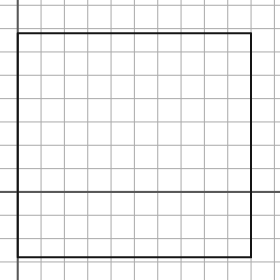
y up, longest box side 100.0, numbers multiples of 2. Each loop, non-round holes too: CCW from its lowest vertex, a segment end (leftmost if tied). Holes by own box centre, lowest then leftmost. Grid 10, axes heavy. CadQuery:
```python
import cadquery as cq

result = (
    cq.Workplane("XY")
    .moveTo(0.0, -28.0)
    .lineTo(100.0, -28.0)
    .lineTo(100.0, 68.0)
    .lineTo(0.0, 68.0)
    .close()
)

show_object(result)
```